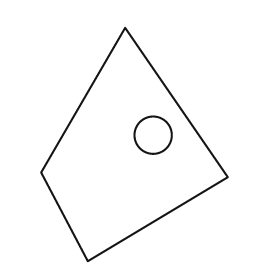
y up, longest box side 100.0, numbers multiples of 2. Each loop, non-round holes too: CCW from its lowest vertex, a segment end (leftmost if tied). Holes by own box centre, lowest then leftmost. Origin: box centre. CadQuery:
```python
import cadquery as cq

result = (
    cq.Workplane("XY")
    .moveTo(-20.0, -50.0)
    .lineTo(40.0, -14.0)
    .lineTo(-4.0, 50.0)
    .lineTo(-40.0, -12.0)
    .close()
    .moveTo(8.0, 4.0)
    .circle(8.0)
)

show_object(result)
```